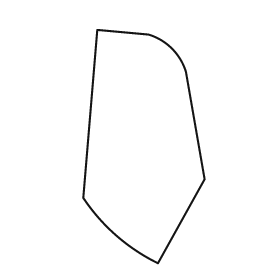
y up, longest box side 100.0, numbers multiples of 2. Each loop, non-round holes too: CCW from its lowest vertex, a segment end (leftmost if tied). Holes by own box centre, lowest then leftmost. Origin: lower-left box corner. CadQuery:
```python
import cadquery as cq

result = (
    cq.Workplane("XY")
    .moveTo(32.0, 0.0)
    .lineTo(52.0, 36.0)
    .lineTo(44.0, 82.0)
    .threePointArc((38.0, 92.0), (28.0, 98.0))
    .lineTo(6.0, 100.0)
    .lineTo(0.0, 28.0)
    .threePointArc((14.0, 12.0), (32.0, 0.0))
    .close()
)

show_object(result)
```